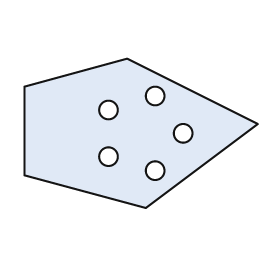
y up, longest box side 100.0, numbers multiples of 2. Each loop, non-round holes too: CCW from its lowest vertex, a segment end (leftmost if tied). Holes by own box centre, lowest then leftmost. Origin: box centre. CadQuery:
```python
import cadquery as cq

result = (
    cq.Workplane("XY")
    .moveTo(2.0, -32.0)
    .lineTo(50.0, 4.0)
    .lineTo(-6.0, 32.0)
    .lineTo(-50.0, 20.0)
    .lineTo(-50.0, -18.0)
    .close()
    .moveTo(6.0, -16.0)
    .circle(4.0)
    .moveTo(-14.0, -10.0)
    .circle(4.0)
    .moveTo(18.0, 0.0)
    .circle(4.0)
    .moveTo(-14.0, 10.0)
    .circle(4.0)
    .moveTo(6.0, 16.0)
    .circle(4.0)
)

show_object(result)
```